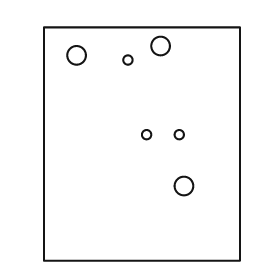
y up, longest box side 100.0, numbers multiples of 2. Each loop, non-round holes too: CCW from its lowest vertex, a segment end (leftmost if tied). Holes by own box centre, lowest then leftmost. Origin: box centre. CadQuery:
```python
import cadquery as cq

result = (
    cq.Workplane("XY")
    .moveTo(-42.0, -50.0)
    .lineTo(42.0, -50.0)
    .lineTo(42.0, 50.0)
    .lineTo(-42.0, 50.0)
    .close()
    .moveTo(18.0, -18.0)
    .circle(4.0)
    .moveTo(2.0, 4.0)
    .circle(2.0)
    .moveTo(16.0, 4.0)
    .circle(2.0)
    .moveTo(-6.0, 36.0)
    .circle(2.0)
    .moveTo(-28.0, 38.0)
    .circle(4.0)
    .moveTo(8.0, 42.0)
    .circle(4.0)
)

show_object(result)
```